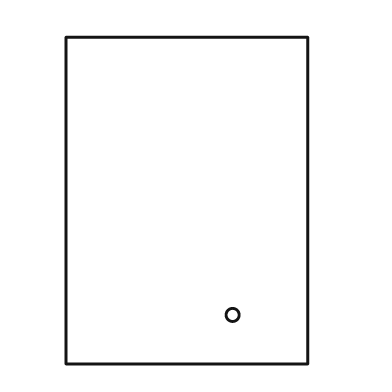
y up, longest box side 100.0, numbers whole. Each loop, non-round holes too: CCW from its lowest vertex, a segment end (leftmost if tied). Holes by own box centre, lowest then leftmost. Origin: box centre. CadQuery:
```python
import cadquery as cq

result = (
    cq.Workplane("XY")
    .moveTo(-37.0, -50.0)
    .lineTo(37.0, -50.0)
    .lineTo(37.0, 50.0)
    .lineTo(-37.0, 50.0)
    .close()
    .moveTo(14.0, -35.0)
    .circle(2.0)
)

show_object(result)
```